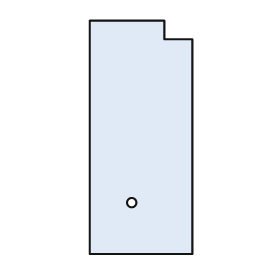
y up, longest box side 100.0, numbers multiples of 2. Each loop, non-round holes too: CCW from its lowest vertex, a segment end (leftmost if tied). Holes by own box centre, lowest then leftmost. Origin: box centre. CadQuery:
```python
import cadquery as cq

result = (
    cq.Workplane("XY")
    .moveTo(-22.0, -50.0)
    .lineTo(22.0, -50.0)
    .lineTo(22.0, 42.0)
    .lineTo(10.0, 42.0)
    .lineTo(10.0, 50.0)
    .lineTo(-22.0, 50.0)
    .close()
    .moveTo(-4.0, -28.0)
    .circle(2.0)
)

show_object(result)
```